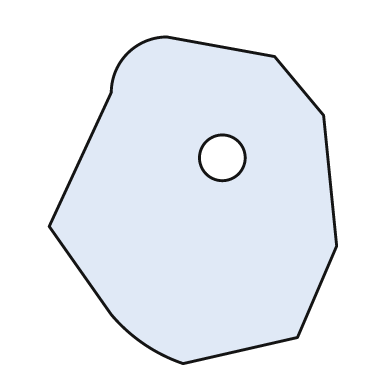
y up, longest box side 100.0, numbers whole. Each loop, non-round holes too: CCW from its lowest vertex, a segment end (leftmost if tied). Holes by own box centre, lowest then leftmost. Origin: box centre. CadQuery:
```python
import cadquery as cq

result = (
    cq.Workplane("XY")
    .moveTo(-3.0, -50.0)
    .lineTo(32.0, -42.0)
    .lineTo(44.0, -14.0)
    .lineTo(40.0, 26.0)
    .lineTo(25.0, 44.0)
    .lineTo(-8.0, 50.0)
    .threePointArc((-20.0, 45.0), (-25.0, 33.0))
    .lineTo(-44.0, -8.0)
    .lineTo(-25.0, -35.0)
    .threePointArc((-15.0, -44.0), (-3.0, -50.0))
    .close()
    .moveTo(9.0, 13.0)
    .circle(7.0)
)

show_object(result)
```